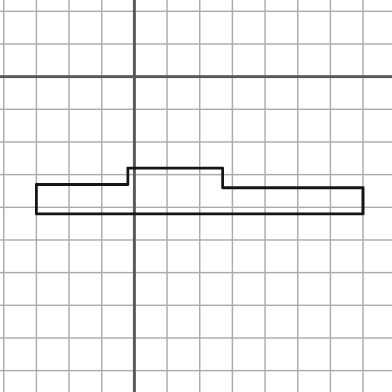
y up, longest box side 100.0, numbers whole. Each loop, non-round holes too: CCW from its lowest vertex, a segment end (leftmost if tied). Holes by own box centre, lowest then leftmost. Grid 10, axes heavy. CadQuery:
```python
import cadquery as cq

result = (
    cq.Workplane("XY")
    .moveTo(-30.0, -42.0)
    .lineTo(70.0, -42.0)
    .lineTo(70.0, -34.0)
    .lineTo(27.0, -34.0)
    .lineTo(27.0, -28.0)
    .lineTo(-2.0, -28.0)
    .lineTo(-2.0, -33.0)
    .lineTo(-30.0, -33.0)
    .close()
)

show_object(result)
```